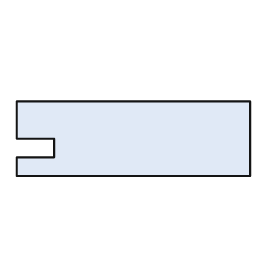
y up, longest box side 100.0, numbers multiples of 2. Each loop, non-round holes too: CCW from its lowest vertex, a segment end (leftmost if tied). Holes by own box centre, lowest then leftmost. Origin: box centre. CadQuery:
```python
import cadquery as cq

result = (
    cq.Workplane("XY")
    .moveTo(-50.0, -16.0)
    .lineTo(50.0, -16.0)
    .lineTo(50.0, 16.0)
    .lineTo(-50.0, 16.0)
    .lineTo(-50.0, 0.0)
    .lineTo(-34.0, 0.0)
    .lineTo(-34.0, -8.0)
    .lineTo(-50.0, -8.0)
    .close()
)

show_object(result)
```